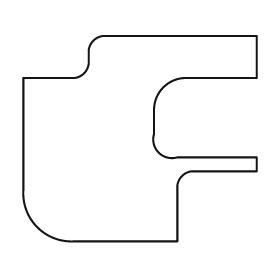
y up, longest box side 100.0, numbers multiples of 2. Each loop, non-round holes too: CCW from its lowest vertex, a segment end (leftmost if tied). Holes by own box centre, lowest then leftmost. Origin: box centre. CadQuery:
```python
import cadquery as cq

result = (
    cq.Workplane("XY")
    .moveTo(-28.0, -44.0)
    .lineTo(16.0, -44.0)
    .lineTo(16.0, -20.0)
    .threePointArc((18.0, -16.0), (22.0, -14.0))
    .lineTo(50.0, -14.0)
    .lineTo(50.0, -8.0)
    .lineTo(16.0, -8.0)
    .threePointArc((8.0, -6.0), (6.0, 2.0))
    .lineTo(6.0, 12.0)
    .threePointArc((10.0, 22.0), (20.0, 26.0))
    .lineTo(50.0, 26.0)
    .lineTo(50.0, 44.0)
    .lineTo(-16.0, 44.0)
    .threePointArc((-20.0, 42.0), (-22.0, 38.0))
    .lineTo(-22.0, 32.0)
    .threePointArc((-24.0, 28.0), (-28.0, 26.0))
    .lineTo(-50.0, 26.0)
    .lineTo(-50.0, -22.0)
    .threePointArc((-44.0, -38.0), (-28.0, -44.0))
    .close()
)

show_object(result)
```